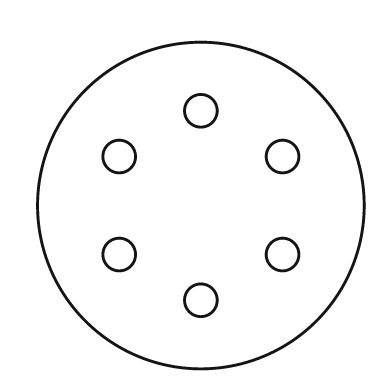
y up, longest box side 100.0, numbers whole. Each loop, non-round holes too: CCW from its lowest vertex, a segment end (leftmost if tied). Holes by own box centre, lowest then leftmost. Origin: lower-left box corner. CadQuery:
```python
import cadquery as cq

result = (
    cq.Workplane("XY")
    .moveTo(50.0, 50.0)
    .circle(50.0)
    .moveTo(50.0, 21.0)
    .circle(5.0)
    .moveTo(25.0, 35.0)
    .circle(5.0)
    .moveTo(75.0, 35.0)
    .circle(5.0)
    .moveTo(25.0, 65.0)
    .circle(5.0)
    .moveTo(75.0, 65.0)
    .circle(5.0)
    .moveTo(50.0, 79.0)
    .circle(5.0)
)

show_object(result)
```